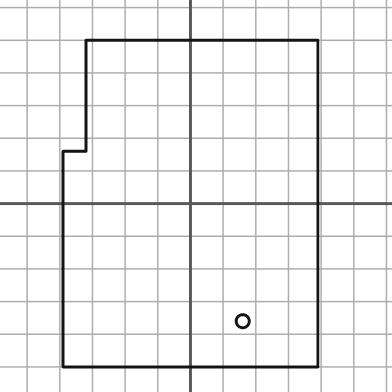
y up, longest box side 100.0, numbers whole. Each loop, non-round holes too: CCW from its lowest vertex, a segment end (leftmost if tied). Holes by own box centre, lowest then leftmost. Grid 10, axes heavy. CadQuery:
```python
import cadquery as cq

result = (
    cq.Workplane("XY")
    .moveTo(-39.0, -50.0)
    .lineTo(39.0, -50.0)
    .lineTo(39.0, 50.0)
    .lineTo(-32.0, 50.0)
    .lineTo(-32.0, 16.0)
    .lineTo(-39.0, 16.0)
    .close()
    .moveTo(16.0, -36.0)
    .circle(2.0)
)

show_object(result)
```